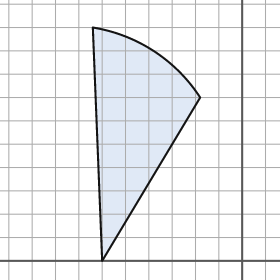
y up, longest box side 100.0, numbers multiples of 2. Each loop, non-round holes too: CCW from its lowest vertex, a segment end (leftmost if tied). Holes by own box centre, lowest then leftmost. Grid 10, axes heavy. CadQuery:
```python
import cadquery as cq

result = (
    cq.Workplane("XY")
    .moveTo(-60.0, 0.0)
    .lineTo(-18.0, 70.0)
    .threePointArc((-38.0, 90.0), (-64.0, 100.0))
    .close()
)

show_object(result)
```